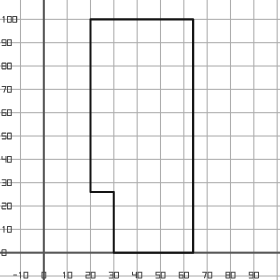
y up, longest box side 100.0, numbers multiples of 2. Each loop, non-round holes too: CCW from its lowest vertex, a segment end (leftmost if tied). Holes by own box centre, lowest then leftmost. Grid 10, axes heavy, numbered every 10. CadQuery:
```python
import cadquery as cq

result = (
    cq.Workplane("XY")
    .moveTo(30.0, 0.0)
    .lineTo(64.0, 0.0)
    .lineTo(64.0, 100.0)
    .lineTo(20.0, 100.0)
    .lineTo(20.0, 26.0)
    .lineTo(30.0, 26.0)
    .close()
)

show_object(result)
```